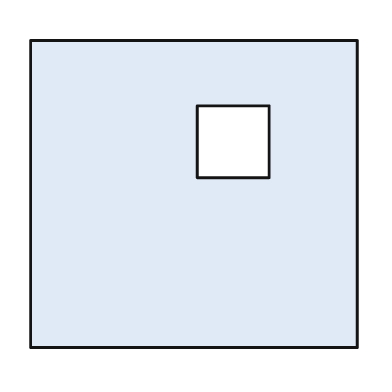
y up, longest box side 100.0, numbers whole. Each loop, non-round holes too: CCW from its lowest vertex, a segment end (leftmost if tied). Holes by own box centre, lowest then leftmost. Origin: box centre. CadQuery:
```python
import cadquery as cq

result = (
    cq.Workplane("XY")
    .moveTo(-50.0, -47.0)
    .lineTo(50.0, -47.0)
    .lineTo(50.0, 47.0)
    .lineTo(-50.0, 47.0)
    .close()
    .moveTo(1.0, 5.0)
    .lineTo(23.0, 5.0)
    .lineTo(23.0, 27.0)
    .lineTo(1.0, 27.0)
    .close()
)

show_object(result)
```